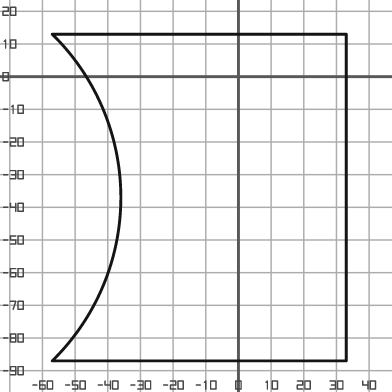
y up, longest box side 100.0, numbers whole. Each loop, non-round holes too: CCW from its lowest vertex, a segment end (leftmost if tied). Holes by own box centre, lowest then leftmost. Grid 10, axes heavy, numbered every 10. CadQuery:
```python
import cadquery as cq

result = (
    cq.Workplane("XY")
    .moveTo(-57.0, -87.0)
    .lineTo(33.0, -87.0)
    .lineTo(33.0, 13.0)
    .lineTo(-57.0, 13.0)
    .threePointArc((-36.0, -37.0), (-57.0, -87.0))
    .close()
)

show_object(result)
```